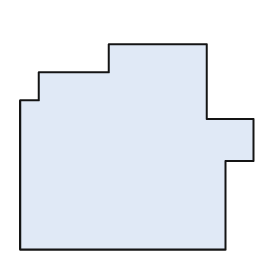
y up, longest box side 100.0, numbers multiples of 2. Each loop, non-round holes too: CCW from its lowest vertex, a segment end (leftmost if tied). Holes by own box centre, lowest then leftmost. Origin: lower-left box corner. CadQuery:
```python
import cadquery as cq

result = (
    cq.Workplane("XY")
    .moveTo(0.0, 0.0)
    .lineTo(88.0, 0.0)
    .lineTo(88.0, 38.0)
    .lineTo(100.0, 38.0)
    .lineTo(100.0, 56.0)
    .lineTo(80.0, 56.0)
    .lineTo(80.0, 88.0)
    .lineTo(38.0, 88.0)
    .lineTo(38.0, 76.0)
    .lineTo(8.0, 76.0)
    .lineTo(8.0, 64.0)
    .lineTo(0.0, 64.0)
    .close()
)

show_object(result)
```